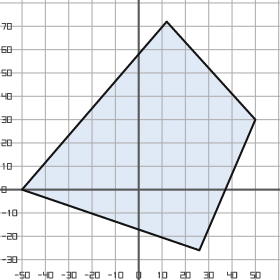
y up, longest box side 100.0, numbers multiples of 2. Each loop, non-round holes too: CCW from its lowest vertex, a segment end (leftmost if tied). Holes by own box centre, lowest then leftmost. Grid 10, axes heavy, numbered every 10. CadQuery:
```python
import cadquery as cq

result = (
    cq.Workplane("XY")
    .moveTo(26.0, -26.0)
    .lineTo(50.0, 30.0)
    .lineTo(12.0, 72.0)
    .lineTo(-50.0, 0.0)
    .close()
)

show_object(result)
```